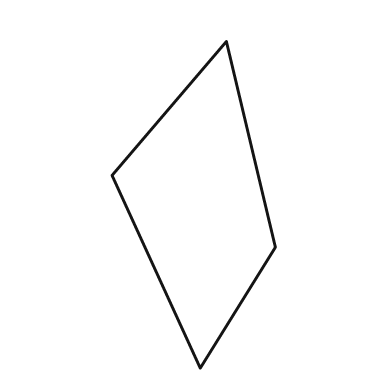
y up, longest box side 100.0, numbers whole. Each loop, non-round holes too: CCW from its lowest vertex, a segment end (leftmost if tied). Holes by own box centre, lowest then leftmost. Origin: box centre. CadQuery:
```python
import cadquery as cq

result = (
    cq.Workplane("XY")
    .moveTo(2.0, -50.0)
    .lineTo(25.0, -13.0)
    .lineTo(10.0, 50.0)
    .lineTo(-25.0, 9.0)
    .close()
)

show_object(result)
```